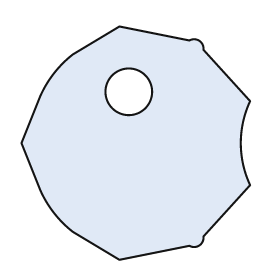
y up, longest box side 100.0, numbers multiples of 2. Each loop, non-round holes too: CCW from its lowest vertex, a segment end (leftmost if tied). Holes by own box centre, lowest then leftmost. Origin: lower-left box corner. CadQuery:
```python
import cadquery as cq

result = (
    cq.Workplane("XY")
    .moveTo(42.0, 0.0)
    .lineTo(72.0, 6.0)
    .threePointArc((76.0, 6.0), (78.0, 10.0))
    .lineTo(98.0, 32.0)
    .threePointArc((94.0, 50.0), (98.0, 68.0))
    .lineTo(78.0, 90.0)
    .threePointArc((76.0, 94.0), (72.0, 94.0))
    .lineTo(42.0, 100.0)
    .lineTo(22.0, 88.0)
    .threePointArc((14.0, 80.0), (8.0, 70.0))
    .lineTo(0.0, 50.0)
    .lineTo(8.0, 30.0)
    .threePointArc((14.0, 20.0), (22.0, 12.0))
    .close()
    .moveTo(46.0, 72.0)
    .circle(10.0)
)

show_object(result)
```